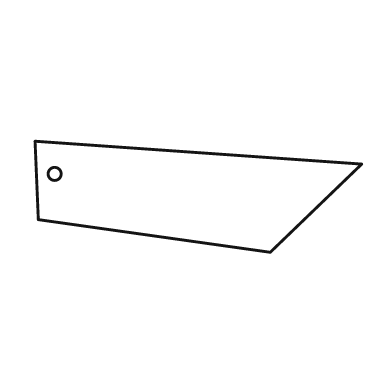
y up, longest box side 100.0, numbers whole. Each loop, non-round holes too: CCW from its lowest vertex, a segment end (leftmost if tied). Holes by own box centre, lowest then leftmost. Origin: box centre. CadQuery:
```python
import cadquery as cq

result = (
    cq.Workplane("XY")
    .moveTo(22.0, -17.0)
    .lineTo(50.0, 10.0)
    .lineTo(-50.0, 17.0)
    .lineTo(-49.0, -7.0)
    .close()
    .moveTo(-44.0, 7.0)
    .circle(2.0)
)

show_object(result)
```